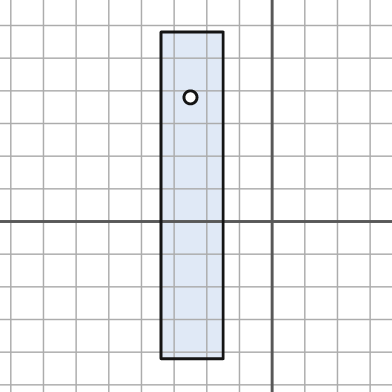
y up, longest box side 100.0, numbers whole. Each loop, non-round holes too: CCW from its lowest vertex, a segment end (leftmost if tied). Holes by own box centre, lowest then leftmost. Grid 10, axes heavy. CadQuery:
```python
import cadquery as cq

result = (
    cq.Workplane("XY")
    .moveTo(-34.0, -42.0)
    .lineTo(-15.0, -42.0)
    .lineTo(-15.0, 58.0)
    .lineTo(-34.0, 58.0)
    .close()
    .moveTo(-25.0, 38.0)
    .circle(2.0)
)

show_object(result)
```